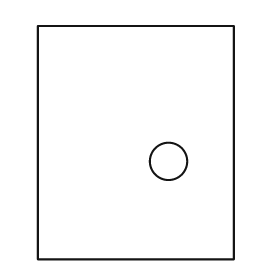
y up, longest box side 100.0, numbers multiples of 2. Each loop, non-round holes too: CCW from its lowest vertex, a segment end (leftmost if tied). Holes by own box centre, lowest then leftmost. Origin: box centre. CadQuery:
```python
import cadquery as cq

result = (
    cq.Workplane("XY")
    .moveTo(-42.0, -50.0)
    .lineTo(42.0, -50.0)
    .lineTo(42.0, 50.0)
    .lineTo(-42.0, 50.0)
    .close()
    .moveTo(14.0, -8.0)
    .circle(8.0)
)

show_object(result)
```